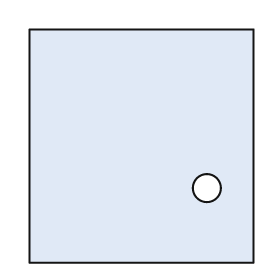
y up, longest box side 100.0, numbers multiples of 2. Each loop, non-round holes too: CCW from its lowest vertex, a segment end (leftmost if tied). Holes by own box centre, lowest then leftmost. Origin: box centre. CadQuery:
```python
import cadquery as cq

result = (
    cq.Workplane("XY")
    .moveTo(-48.0, -50.0)
    .lineTo(48.0, -50.0)
    .lineTo(48.0, 50.0)
    .lineTo(-48.0, 50.0)
    .close()
    .moveTo(28.0, -18.0)
    .circle(6.0)
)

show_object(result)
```